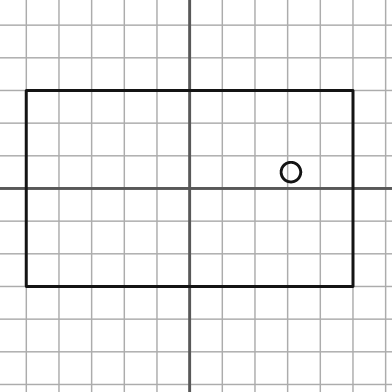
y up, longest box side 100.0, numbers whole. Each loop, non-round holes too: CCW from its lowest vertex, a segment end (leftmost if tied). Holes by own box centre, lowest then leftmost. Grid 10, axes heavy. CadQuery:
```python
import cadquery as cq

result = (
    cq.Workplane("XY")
    .moveTo(-50.0, -30.0)
    .lineTo(50.0, -30.0)
    .lineTo(50.0, 30.0)
    .lineTo(-50.0, 30.0)
    .close()
    .moveTo(31.0, 5.0)
    .circle(3.0)
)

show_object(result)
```